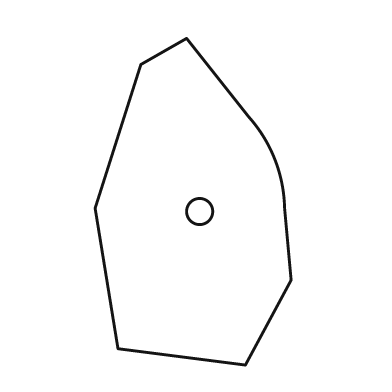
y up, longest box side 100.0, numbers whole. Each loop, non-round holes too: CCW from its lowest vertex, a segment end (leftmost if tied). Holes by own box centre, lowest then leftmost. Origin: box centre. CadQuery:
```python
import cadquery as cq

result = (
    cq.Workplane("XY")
    .moveTo(16.0, -50.0)
    .lineTo(30.0, -24.0)
    .lineTo(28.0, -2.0)
    .threePointArc((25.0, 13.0), (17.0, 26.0))
    .lineTo(-2.0, 50.0)
    .lineTo(-16.0, 42.0)
    .lineTo(-30.0, -2.0)
    .lineTo(-23.0, -45.0)
    .close()
    .moveTo(2.0, -3.0)
    .circle(4.0)
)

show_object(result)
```